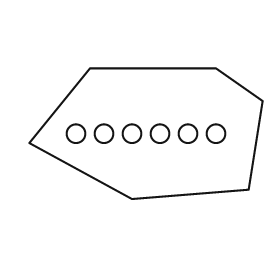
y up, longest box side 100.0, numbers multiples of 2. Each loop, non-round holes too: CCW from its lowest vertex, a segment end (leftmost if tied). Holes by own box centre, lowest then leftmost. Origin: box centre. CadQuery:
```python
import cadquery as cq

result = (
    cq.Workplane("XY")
    .moveTo(-6.0, -28.0)
    .lineTo(44.0, -24.0)
    .lineTo(50.0, 14.0)
    .lineTo(30.0, 28.0)
    .lineTo(-24.0, 28.0)
    .lineTo(-50.0, -4.0)
    .close()
    .moveTo(-30.0, 0.0)
    .circle(4.0)
    .moveTo(-18.0, 0.0)
    .circle(4.0)
    .moveTo(-6.0, 0.0)
    .circle(4.0)
    .moveTo(6.0, 0.0)
    .circle(4.0)
    .moveTo(18.0, 0.0)
    .circle(4.0)
    .moveTo(30.0, 0.0)
    .circle(4.0)
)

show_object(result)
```